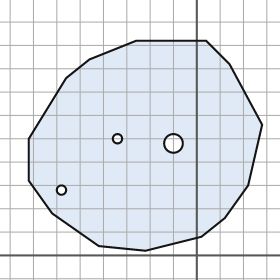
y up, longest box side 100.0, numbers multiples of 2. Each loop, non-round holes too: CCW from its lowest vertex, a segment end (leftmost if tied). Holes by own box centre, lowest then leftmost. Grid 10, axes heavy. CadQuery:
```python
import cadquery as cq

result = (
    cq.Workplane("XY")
    .moveTo(-22.0, 2.0)
    .lineTo(2.0, 8.0)
    .lineTo(12.0, 16.0)
    .lineTo(22.0, 30.0)
    .lineTo(28.0, 56.0)
    .lineTo(14.0, 82.0)
    .lineTo(4.0, 92.0)
    .lineTo(-26.0, 92.0)
    .lineTo(-46.0, 84.0)
    .lineTo(-56.0, 76.0)
    .lineTo(-72.0, 50.0)
    .lineTo(-72.0, 32.0)
    .lineTo(-62.0, 18.0)
    .lineTo(-42.0, 4.0)
    .close()
    .moveTo(-58.0, 28.0)
    .circle(2.0)
    .moveTo(-10.0, 48.0)
    .circle(4.0)
    .moveTo(-34.0, 50.0)
    .circle(2.0)
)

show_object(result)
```